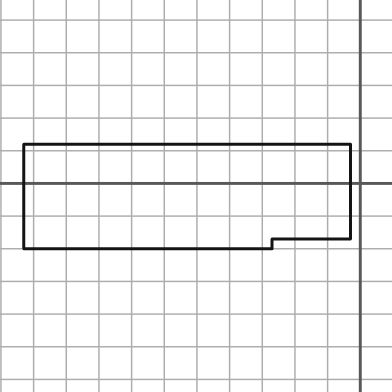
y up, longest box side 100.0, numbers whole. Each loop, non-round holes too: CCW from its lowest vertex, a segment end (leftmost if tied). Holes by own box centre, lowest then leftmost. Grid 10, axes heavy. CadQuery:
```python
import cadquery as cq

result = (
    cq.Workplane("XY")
    .moveTo(-103.0, -20.0)
    .lineTo(-27.0, -20.0)
    .lineTo(-27.0, -17.0)
    .lineTo(-3.0, -17.0)
    .lineTo(-3.0, 12.0)
    .lineTo(-103.0, 12.0)
    .close()
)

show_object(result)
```